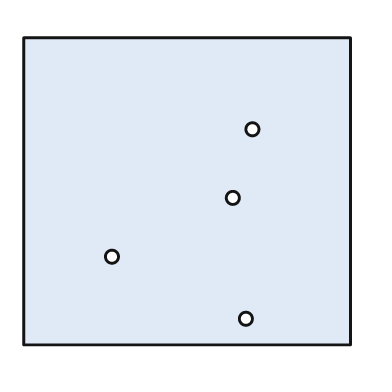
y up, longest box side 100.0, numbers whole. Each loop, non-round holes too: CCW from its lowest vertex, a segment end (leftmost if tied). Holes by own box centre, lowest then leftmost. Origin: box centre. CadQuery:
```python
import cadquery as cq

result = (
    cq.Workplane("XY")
    .moveTo(-50.0, -47.0)
    .lineTo(50.0, -47.0)
    .lineTo(50.0, 47.0)
    .lineTo(-50.0, 47.0)
    .close()
    .moveTo(18.0, -39.0)
    .circle(2.0)
    .moveTo(-23.0, -20.0)
    .circle(2.0)
    .moveTo(14.0, -2.0)
    .circle(2.0)
    .moveTo(20.0, 19.0)
    .circle(2.0)
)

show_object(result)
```